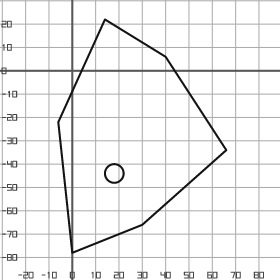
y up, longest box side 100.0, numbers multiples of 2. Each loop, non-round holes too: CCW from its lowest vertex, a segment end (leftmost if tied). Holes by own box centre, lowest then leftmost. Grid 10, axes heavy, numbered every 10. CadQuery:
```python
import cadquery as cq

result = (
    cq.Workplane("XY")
    .moveTo(0.0, -78.0)
    .lineTo(30.0, -66.0)
    .lineTo(66.0, -34.0)
    .lineTo(40.0, 6.0)
    .lineTo(14.0, 22.0)
    .lineTo(-6.0, -22.0)
    .close()
    .moveTo(18.0, -44.0)
    .circle(4.0)
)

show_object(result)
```